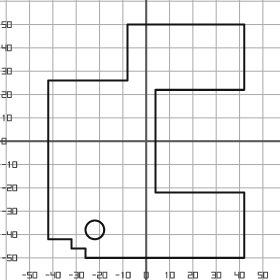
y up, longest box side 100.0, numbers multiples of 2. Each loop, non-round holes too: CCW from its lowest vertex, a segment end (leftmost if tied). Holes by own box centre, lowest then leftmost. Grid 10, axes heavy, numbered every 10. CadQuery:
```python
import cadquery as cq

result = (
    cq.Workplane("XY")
    .moveTo(-26.0, -50.0)
    .lineTo(42.0, -50.0)
    .lineTo(42.0, -22.0)
    .lineTo(4.0, -22.0)
    .lineTo(4.0, 22.0)
    .lineTo(42.0, 22.0)
    .lineTo(42.0, 50.0)
    .lineTo(-8.0, 50.0)
    .lineTo(-8.0, 26.0)
    .lineTo(-42.0, 26.0)
    .lineTo(-42.0, -42.0)
    .lineTo(-32.0, -42.0)
    .lineTo(-32.0, -46.0)
    .lineTo(-26.0, -46.0)
    .close()
    .moveTo(-22.0, -38.0)
    .circle(4.0)
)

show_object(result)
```